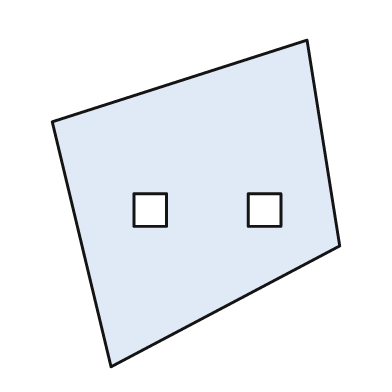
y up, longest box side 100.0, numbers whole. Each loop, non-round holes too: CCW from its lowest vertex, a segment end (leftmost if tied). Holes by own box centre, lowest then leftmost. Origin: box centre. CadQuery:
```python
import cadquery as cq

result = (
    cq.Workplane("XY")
    .moveTo(-26.0, -50.0)
    .lineTo(44.0, -13.0)
    .lineTo(34.0, 50.0)
    .lineTo(-44.0, 25.0)
    .close()
    .moveTo(-19.0, -7.0)
    .lineTo(-9.0, -7.0)
    .lineTo(-9.0, 3.0)
    .lineTo(-19.0, 3.0)
    .close()
    .moveTo(16.0, -7.0)
    .lineTo(26.0, -7.0)
    .lineTo(26.0, 3.0)
    .lineTo(16.0, 3.0)
    .close()
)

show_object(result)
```